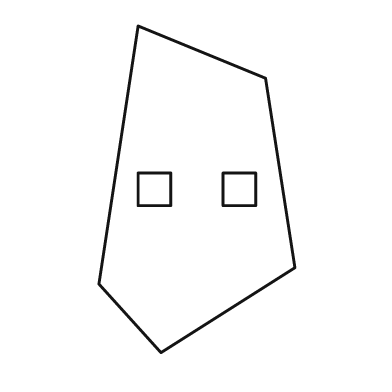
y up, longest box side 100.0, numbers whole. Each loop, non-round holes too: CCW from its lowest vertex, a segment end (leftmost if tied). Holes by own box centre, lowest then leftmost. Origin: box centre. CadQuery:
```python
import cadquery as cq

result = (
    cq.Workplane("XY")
    .moveTo(-11.0, -50.0)
    .lineTo(30.0, -24.0)
    .lineTo(21.0, 34.0)
    .lineTo(-18.0, 50.0)
    .lineTo(-30.0, -29.0)
    .close()
    .moveTo(-18.0, -5.0)
    .lineTo(-8.0, -5.0)
    .lineTo(-8.0, 5.0)
    .lineTo(-18.0, 5.0)
    .close()
    .moveTo(8.0, -5.0)
    .lineTo(18.0, -5.0)
    .lineTo(18.0, 5.0)
    .lineTo(8.0, 5.0)
    .close()
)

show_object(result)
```